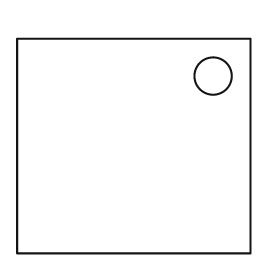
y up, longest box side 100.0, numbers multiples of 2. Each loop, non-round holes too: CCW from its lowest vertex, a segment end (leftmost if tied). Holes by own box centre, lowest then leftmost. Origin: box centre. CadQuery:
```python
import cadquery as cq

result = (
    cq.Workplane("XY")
    .moveTo(-50.0, -46.0)
    .lineTo(50.0, -46.0)
    .lineTo(50.0, 46.0)
    .lineTo(-50.0, 46.0)
    .close()
    .moveTo(34.0, 30.0)
    .circle(8.0)
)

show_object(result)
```